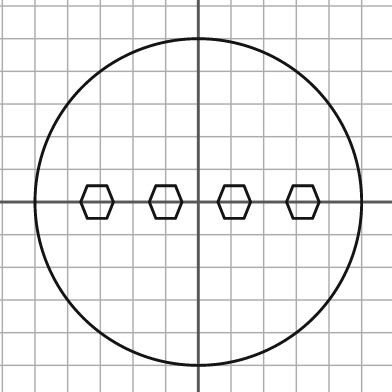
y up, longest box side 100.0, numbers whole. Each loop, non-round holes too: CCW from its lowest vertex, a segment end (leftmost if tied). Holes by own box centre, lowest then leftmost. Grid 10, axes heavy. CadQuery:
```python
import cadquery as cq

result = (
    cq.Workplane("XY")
    .moveTo(0.0, 0.0)
    .circle(50.0)
    .moveTo(-34.0, -5.0)
    .lineTo(-28.0, -5.0)
    .lineTo(-26.0, 0.0)
    .lineTo(-28.0, 5.0)
    .lineTo(-34.0, 5.0)
    .lineTo(-36.0, 0.0)
    .close()
    .moveTo(-13.0, -5.0)
    .lineTo(-7.0, -5.0)
    .lineTo(-5.0, 0.0)
    .lineTo(-7.0, 5.0)
    .lineTo(-13.0, 5.0)
    .lineTo(-15.0, 0.0)
    .close()
    .moveTo(8.0, -5.0)
    .lineTo(14.0, -5.0)
    .lineTo(16.0, 0.0)
    .lineTo(14.0, 5.0)
    .lineTo(8.0, 5.0)
    .lineTo(6.0, 0.0)
    .close()
    .moveTo(29.0, -5.0)
    .lineTo(35.0, -5.0)
    .lineTo(37.0, 0.0)
    .lineTo(35.0, 5.0)
    .lineTo(29.0, 5.0)
    .lineTo(27.0, 0.0)
    .close()
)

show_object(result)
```